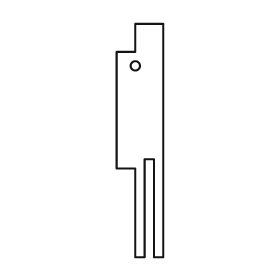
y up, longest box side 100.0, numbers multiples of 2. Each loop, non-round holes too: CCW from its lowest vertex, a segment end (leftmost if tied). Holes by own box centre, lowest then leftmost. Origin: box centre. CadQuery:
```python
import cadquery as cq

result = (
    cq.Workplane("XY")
    .moveTo(-2.0, -50.0)
    .lineTo(2.0, -50.0)
    .lineTo(2.0, -8.0)
    .lineTo(6.0, -8.0)
    .lineTo(6.0, -50.0)
    .lineTo(10.0, -50.0)
    .lineTo(10.0, 50.0)
    .lineTo(-2.0, 50.0)
    .lineTo(-2.0, 38.0)
    .lineTo(-10.0, 38.0)
    .lineTo(-10.0, -12.0)
    .lineTo(-2.0, -12.0)
    .close()
    .moveTo(-2.0, 32.0)
    .circle(2.0)
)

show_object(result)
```